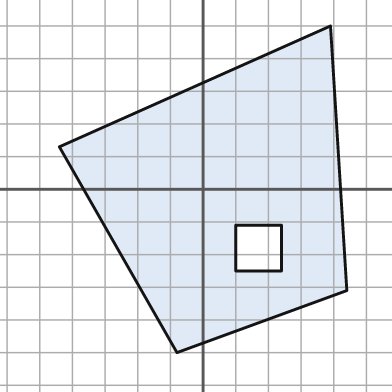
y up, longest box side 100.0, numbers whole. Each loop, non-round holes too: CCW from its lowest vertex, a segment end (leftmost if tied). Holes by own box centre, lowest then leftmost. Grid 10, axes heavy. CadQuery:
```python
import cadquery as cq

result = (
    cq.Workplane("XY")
    .moveTo(-8.0, -50.0)
    .lineTo(44.0, -31.0)
    .lineTo(39.0, 50.0)
    .lineTo(-44.0, 13.0)
    .close()
    .moveTo(10.0, -25.0)
    .lineTo(24.0, -25.0)
    .lineTo(24.0, -11.0)
    .lineTo(10.0, -11.0)
    .close()
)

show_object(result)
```